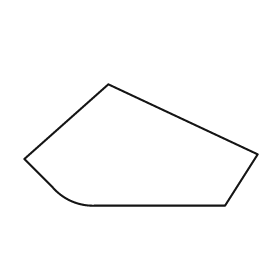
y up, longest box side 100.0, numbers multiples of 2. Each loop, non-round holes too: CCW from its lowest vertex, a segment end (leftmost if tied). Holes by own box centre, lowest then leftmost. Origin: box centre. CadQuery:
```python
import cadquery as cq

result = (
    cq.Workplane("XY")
    .moveTo(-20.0, -26.0)
    .lineTo(36.0, -26.0)
    .lineTo(50.0, -4.0)
    .lineTo(-14.0, 26.0)
    .lineTo(-50.0, -6.0)
    .lineTo(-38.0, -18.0)
    .threePointArc((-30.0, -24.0), (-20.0, -26.0))
    .close()
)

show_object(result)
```